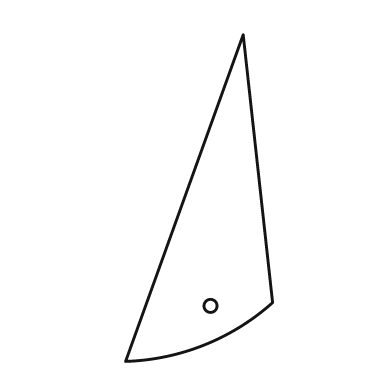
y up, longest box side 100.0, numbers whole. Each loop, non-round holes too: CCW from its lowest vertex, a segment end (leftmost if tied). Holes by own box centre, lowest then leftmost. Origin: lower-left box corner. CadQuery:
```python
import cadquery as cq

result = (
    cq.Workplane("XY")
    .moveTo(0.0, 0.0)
    .threePointArc((24.0, 5.0), (45.0, 18.0))
    .lineTo(36.0, 100.0)
    .close()
    .moveTo(26.0, 17.0)
    .circle(2.0)
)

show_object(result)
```